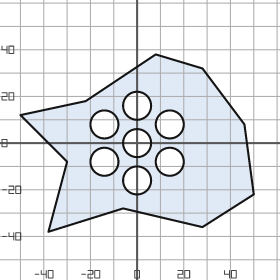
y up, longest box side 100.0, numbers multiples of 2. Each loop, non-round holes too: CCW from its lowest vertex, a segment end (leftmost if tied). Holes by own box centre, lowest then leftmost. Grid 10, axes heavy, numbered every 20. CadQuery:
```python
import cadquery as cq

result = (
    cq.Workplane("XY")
    .moveTo(-38.0, -38.0)
    .lineTo(-6.0, -28.0)
    .lineTo(28.0, -36.0)
    .lineTo(50.0, -22.0)
    .lineTo(46.0, 8.0)
    .lineTo(28.0, 32.0)
    .lineTo(8.0, 38.0)
    .lineTo(-22.0, 18.0)
    .lineTo(-50.0, 12.0)
    .lineTo(-30.0, -8.0)
    .close()
    .moveTo(0.0, -16.0)
    .circle(6.0)
    .moveTo(-14.0, -8.0)
    .circle(6.0)
    .moveTo(14.0, -8.0)
    .circle(6.0)
    .moveTo(0.0, 0.0)
    .circle(6.0)
    .moveTo(-14.0, 8.0)
    .circle(6.0)
    .moveTo(14.0, 8.0)
    .circle(6.0)
    .moveTo(0.0, 16.0)
    .circle(6.0)
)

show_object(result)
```